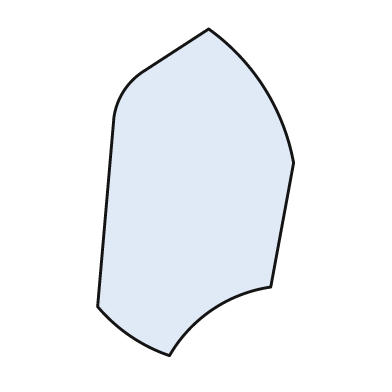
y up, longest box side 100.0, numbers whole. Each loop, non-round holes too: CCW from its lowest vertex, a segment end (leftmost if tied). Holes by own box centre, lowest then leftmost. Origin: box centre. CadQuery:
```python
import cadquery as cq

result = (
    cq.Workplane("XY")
    .moveTo(-8.0, -50.0)
    .threePointArc((5.0, -36.0), (23.0, -29.0))
    .lineTo(30.0, 9.0)
    .threePointArc((21.0, 32.0), (4.0, 50.0))
    .lineTo(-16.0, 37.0)
    .threePointArc((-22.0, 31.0), (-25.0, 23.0))
    .lineTo(-30.0, -35.0)
    .threePointArc((-20.0, -44.0), (-8.0, -50.0))
    .close()
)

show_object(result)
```